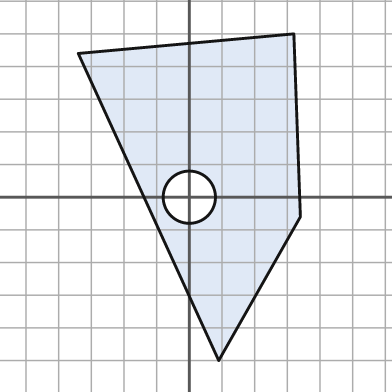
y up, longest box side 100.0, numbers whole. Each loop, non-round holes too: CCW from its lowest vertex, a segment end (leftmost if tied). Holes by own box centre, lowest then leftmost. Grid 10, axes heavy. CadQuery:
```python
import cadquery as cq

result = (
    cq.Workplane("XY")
    .moveTo(9.0, -50.0)
    .lineTo(34.0, -6.0)
    .lineTo(32.0, 50.0)
    .lineTo(-34.0, 44.0)
    .close()
    .moveTo(0.0, 0.0)
    .circle(8.0)
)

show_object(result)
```